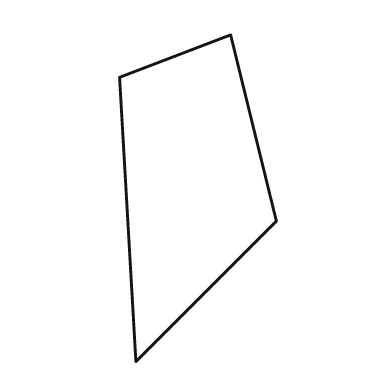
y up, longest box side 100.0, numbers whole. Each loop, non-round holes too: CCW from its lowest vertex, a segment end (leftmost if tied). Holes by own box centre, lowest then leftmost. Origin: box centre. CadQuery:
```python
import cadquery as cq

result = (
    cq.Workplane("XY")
    .moveTo(-19.0, -50.0)
    .lineTo(24.0, -7.0)
    .lineTo(10.0, 50.0)
    .lineTo(-24.0, 37.0)
    .close()
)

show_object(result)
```